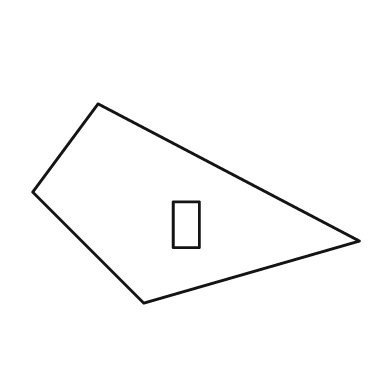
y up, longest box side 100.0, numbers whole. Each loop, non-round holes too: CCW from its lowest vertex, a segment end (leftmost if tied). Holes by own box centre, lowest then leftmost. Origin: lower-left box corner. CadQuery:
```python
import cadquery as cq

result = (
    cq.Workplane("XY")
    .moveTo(34.0, 0.0)
    .lineTo(100.0, 19.0)
    .lineTo(20.0, 61.0)
    .lineTo(0.0, 34.0)
    .close()
    .moveTo(43.0, 17.0)
    .lineTo(51.0, 17.0)
    .lineTo(51.0, 31.0)
    .lineTo(43.0, 31.0)
    .close()
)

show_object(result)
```